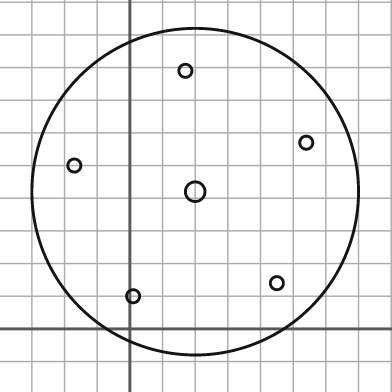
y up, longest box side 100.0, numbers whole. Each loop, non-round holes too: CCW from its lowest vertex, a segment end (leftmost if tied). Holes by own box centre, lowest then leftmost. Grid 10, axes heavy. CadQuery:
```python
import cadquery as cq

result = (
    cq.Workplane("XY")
    .moveTo(20.0, 42.0)
    .circle(50.0)
    .moveTo(1.0, 10.0)
    .circle(2.0)
    .moveTo(45.0, 14.0)
    .circle(2.0)
    .moveTo(20.0, 42.0)
    .circle(3.0)
    .moveTo(-17.0, 50.0)
    .circle(2.0)
    .moveTo(54.0, 57.0)
    .circle(2.0)
    .moveTo(17.0, 79.0)
    .circle(2.0)
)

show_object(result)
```